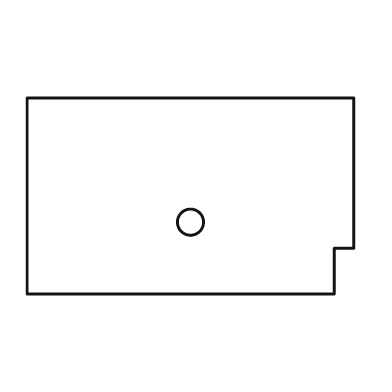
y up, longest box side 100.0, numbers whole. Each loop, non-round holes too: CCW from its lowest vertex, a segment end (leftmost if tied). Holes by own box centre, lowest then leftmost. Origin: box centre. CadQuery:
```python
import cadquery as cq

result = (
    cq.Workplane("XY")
    .moveTo(-50.0, -30.0)
    .lineTo(44.0, -30.0)
    .lineTo(44.0, -16.0)
    .lineTo(50.0, -16.0)
    .lineTo(50.0, 30.0)
    .lineTo(-50.0, 30.0)
    .close()
    .moveTo(0.0, -8.0)
    .circle(4.0)
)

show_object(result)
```